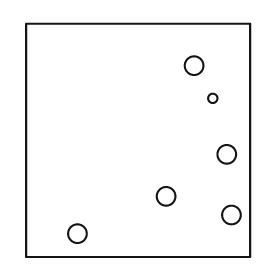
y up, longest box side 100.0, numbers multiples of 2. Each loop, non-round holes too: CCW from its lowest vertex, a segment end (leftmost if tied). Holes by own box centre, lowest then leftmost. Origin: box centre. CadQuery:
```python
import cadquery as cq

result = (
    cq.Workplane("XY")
    .moveTo(-48.0, -50.0)
    .lineTo(48.0, -50.0)
    .lineTo(48.0, 50.0)
    .lineTo(-48.0, 50.0)
    .close()
    .moveTo(-26.0, -40.0)
    .circle(4.0)
    .moveTo(40.0, -32.0)
    .circle(4.0)
    .moveTo(12.0, -24.0)
    .circle(4.0)
    .moveTo(38.0, -6.0)
    .circle(4.0)
    .moveTo(32.0, 18.0)
    .circle(2.0)
    .moveTo(24.0, 32.0)
    .circle(4.0)
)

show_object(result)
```